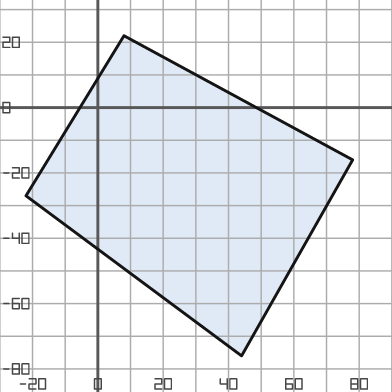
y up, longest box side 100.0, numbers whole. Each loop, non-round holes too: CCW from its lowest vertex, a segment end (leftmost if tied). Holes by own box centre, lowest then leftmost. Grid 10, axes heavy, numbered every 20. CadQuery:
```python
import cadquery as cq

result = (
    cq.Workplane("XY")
    .moveTo(44.0, -76.0)
    .lineTo(78.0, -16.0)
    .lineTo(8.0, 22.0)
    .lineTo(-22.0, -27.0)
    .close()
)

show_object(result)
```